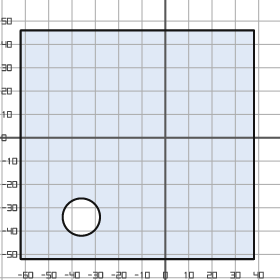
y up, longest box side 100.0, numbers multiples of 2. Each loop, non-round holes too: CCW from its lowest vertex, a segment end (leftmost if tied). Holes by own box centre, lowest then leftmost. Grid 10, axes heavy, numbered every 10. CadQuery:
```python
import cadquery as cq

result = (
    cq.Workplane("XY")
    .moveTo(-62.0, -52.0)
    .lineTo(38.0, -52.0)
    .lineTo(38.0, 46.0)
    .lineTo(-62.0, 46.0)
    .close()
    .moveTo(-36.0, -34.0)
    .circle(8.0)
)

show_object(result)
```